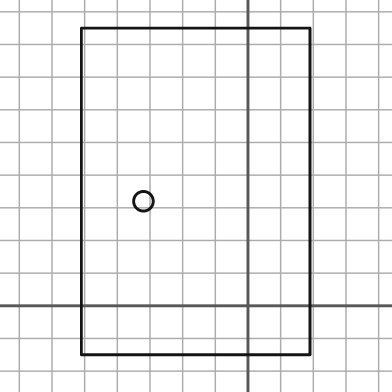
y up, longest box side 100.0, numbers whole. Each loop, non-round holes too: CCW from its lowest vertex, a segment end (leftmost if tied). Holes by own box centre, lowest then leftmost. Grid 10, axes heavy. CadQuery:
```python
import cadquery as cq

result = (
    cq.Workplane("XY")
    .moveTo(-51.0, -15.0)
    .lineTo(19.0, -15.0)
    .lineTo(19.0, 85.0)
    .lineTo(-51.0, 85.0)
    .close()
    .moveTo(-32.0, 32.0)
    .circle(3.0)
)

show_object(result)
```